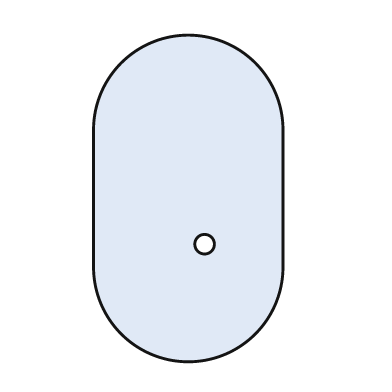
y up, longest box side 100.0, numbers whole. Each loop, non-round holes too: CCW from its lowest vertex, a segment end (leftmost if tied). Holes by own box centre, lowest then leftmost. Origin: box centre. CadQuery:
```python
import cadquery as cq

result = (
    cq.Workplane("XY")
    .moveTo(-29.0, -21.0)
    .threePointArc((0.0, -50.0), (29.0, -21.0))
    .lineTo(29.0, 21.0)
    .threePointArc((0.0, 50.0), (-29.0, 21.0))
    .close()
    .moveTo(5.0, -14.0)
    .circle(3.0)
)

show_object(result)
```